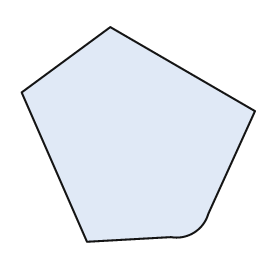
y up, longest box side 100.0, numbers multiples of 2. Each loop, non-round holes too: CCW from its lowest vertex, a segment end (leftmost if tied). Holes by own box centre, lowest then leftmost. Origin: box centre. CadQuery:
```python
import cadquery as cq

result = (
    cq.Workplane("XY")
    .moveTo(-22.0, -46.0)
    .lineTo(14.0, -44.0)
    .threePointArc((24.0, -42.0), (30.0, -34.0))
    .lineTo(50.0, 10.0)
    .lineTo(-12.0, 46.0)
    .lineTo(-50.0, 18.0)
    .close()
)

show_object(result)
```